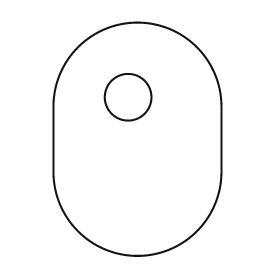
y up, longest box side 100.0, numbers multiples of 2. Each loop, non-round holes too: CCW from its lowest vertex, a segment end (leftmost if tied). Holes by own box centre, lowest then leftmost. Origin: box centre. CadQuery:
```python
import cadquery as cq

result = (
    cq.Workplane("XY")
    .moveTo(-36.0, -14.0)
    .threePointArc((0.0, -50.0), (36.0, -14.0))
    .lineTo(36.0, 14.0)
    .threePointArc((0.0, 50.0), (-36.0, 14.0))
    .close()
    .moveTo(-4.0, 18.0)
    .circle(10.0)
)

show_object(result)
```